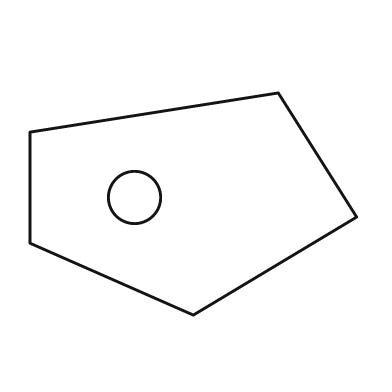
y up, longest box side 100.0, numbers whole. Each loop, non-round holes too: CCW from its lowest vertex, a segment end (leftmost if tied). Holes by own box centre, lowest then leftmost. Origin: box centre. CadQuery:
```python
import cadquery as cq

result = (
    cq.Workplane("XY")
    .moveTo(0.0, -34.0)
    .lineTo(50.0, -4.0)
    .lineTo(26.0, 34.0)
    .lineTo(-50.0, 22.0)
    .lineTo(-50.0, -12.0)
    .close()
    .moveTo(-18.0, 2.0)
    .circle(8.0)
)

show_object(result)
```